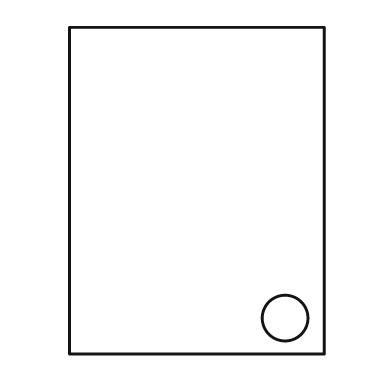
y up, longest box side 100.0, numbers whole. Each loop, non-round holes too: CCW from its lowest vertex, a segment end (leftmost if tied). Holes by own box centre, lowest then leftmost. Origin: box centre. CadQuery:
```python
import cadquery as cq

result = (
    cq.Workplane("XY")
    .moveTo(-39.0, -50.0)
    .lineTo(39.0, -50.0)
    .lineTo(39.0, 50.0)
    .lineTo(-39.0, 50.0)
    .close()
    .moveTo(27.0, -39.0)
    .circle(7.0)
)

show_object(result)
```